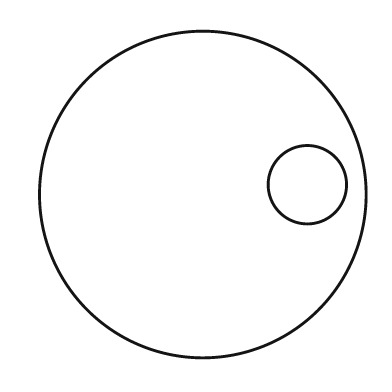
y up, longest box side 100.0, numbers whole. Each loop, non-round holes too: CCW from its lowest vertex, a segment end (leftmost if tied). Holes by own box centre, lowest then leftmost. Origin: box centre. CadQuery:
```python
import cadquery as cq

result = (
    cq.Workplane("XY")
    .moveTo(0.0, 0.0)
    .circle(50.0)
    .moveTo(32.0, 3.0)
    .circle(12.0)
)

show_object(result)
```